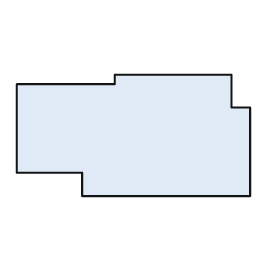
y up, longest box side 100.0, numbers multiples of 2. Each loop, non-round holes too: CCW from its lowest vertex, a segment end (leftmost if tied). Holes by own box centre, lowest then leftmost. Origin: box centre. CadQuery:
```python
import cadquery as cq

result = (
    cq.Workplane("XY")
    .moveTo(-22.0, -26.0)
    .lineTo(50.0, -26.0)
    .lineTo(50.0, 12.0)
    .lineTo(42.0, 12.0)
    .lineTo(42.0, 26.0)
    .lineTo(-8.0, 26.0)
    .lineTo(-8.0, 22.0)
    .lineTo(-50.0, 22.0)
    .lineTo(-50.0, -16.0)
    .lineTo(-22.0, -16.0)
    .close()
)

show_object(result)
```